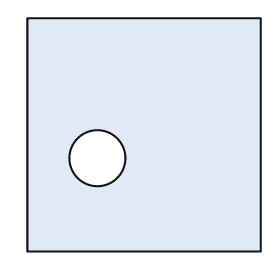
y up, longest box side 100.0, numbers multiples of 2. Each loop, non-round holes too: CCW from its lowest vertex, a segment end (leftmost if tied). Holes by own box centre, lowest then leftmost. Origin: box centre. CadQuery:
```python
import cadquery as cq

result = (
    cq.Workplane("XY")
    .moveTo(-50.0, -50.0)
    .lineTo(50.0, -50.0)
    .lineTo(50.0, 50.0)
    .lineTo(-50.0, 50.0)
    .close()
    .moveTo(-20.0, -10.0)
    .circle(12.0)
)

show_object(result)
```